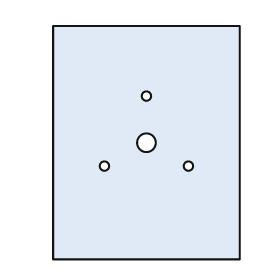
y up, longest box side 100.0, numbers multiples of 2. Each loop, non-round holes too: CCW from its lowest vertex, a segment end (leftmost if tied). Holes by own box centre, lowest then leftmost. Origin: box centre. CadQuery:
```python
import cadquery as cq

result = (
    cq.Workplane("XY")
    .moveTo(-40.0, -50.0)
    .lineTo(40.0, -50.0)
    .lineTo(40.0, 50.0)
    .lineTo(-40.0, 50.0)
    .close()
    .moveTo(-18.0, -10.0)
    .circle(2.0)
    .moveTo(18.0, -10.0)
    .circle(2.0)
    .moveTo(0.0, 0.0)
    .circle(4.0)
    .moveTo(0.0, 20.0)
    .circle(2.0)
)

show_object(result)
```